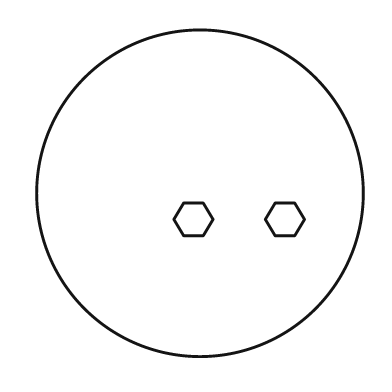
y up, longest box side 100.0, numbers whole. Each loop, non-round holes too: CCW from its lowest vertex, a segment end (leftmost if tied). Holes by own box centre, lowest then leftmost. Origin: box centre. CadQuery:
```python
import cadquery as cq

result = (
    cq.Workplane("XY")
    .moveTo(0.0, 0.0)
    .circle(50.0)
    .moveTo(-5.0, -13.0)
    .lineTo(1.0, -13.0)
    .lineTo(4.0, -8.0)
    .lineTo(1.0, -3.0)
    .lineTo(-5.0, -3.0)
    .lineTo(-8.0, -8.0)
    .close()
    .moveTo(23.0, -13.0)
    .lineTo(29.0, -13.0)
    .lineTo(32.0, -8.0)
    .lineTo(29.0, -3.0)
    .lineTo(23.0, -3.0)
    .lineTo(20.0, -8.0)
    .close()
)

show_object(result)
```